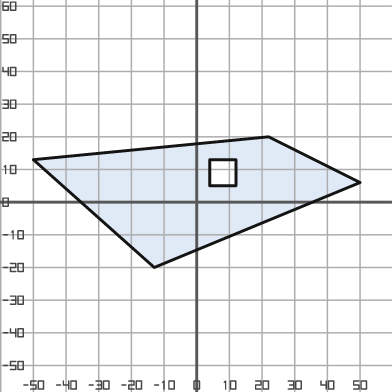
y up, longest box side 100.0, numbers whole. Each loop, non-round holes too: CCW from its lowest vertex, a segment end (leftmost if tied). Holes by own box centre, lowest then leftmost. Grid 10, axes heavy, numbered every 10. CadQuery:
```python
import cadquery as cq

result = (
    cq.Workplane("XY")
    .moveTo(-13.0, -20.0)
    .lineTo(50.0, 6.0)
    .lineTo(22.0, 20.0)
    .lineTo(-50.0, 13.0)
    .close()
    .moveTo(4.0, 5.0)
    .lineTo(12.0, 5.0)
    .lineTo(12.0, 13.0)
    .lineTo(4.0, 13.0)
    .close()
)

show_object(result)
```